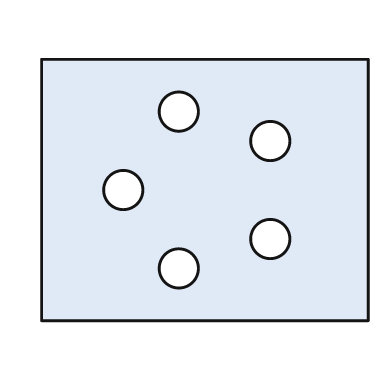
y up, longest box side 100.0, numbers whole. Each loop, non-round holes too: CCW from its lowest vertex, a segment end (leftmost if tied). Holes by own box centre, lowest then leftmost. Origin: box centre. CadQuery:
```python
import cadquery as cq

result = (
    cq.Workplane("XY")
    .moveTo(-50.0, -40.0)
    .lineTo(50.0, -40.0)
    .lineTo(50.0, 40.0)
    .lineTo(-50.0, 40.0)
    .close()
    .moveTo(-8.0, -24.0)
    .circle(6.0)
    .moveTo(20.0, -15.0)
    .circle(6.0)
    .moveTo(-25.0, 0.0)
    .circle(6.0)
    .moveTo(20.0, 15.0)
    .circle(6.0)
    .moveTo(-8.0, 24.0)
    .circle(6.0)
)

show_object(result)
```